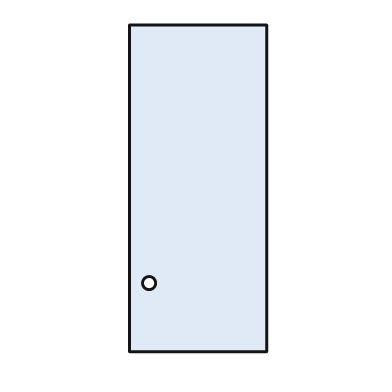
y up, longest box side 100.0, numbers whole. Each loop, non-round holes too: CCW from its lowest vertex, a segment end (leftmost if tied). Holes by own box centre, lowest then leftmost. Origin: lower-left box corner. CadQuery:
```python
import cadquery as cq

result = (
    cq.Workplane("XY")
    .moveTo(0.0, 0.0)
    .lineTo(42.0, 0.0)
    .lineTo(42.0, 100.0)
    .lineTo(0.0, 100.0)
    .close()
    .moveTo(6.0, 21.0)
    .circle(2.0)
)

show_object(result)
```